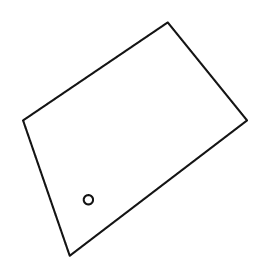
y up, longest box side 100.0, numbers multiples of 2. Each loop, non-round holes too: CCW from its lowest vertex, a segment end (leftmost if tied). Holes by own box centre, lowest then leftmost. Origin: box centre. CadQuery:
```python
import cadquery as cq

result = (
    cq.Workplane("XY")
    .moveTo(-28.0, -50.0)
    .lineTo(48.0, 8.0)
    .lineTo(14.0, 50.0)
    .lineTo(-48.0, 8.0)
    .close()
    .moveTo(-20.0, -26.0)
    .circle(2.0)
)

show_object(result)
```